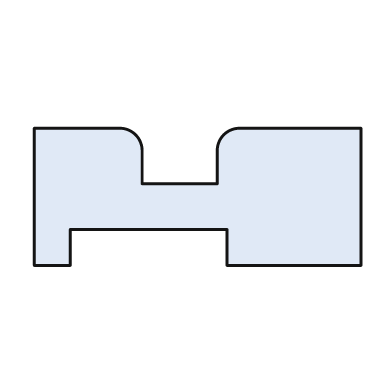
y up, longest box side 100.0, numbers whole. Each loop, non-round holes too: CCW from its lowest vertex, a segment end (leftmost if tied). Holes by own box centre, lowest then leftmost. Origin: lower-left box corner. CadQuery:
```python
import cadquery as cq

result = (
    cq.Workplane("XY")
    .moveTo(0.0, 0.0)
    .lineTo(11.0, 0.0)
    .lineTo(11.0, 11.0)
    .lineTo(59.0, 11.0)
    .lineTo(59.0, 0.0)
    .lineTo(100.0, 0.0)
    .lineTo(100.0, 42.0)
    .lineTo(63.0, 42.0)
    .threePointArc((58.0, 40.0), (56.0, 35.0))
    .lineTo(56.0, 25.0)
    .lineTo(33.0, 25.0)
    .lineTo(33.0, 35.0)
    .threePointArc((31.0, 40.0), (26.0, 42.0))
    .lineTo(0.0, 42.0)
    .close()
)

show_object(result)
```